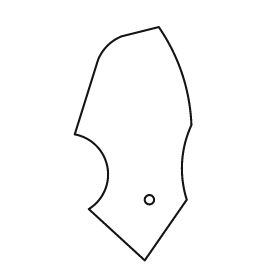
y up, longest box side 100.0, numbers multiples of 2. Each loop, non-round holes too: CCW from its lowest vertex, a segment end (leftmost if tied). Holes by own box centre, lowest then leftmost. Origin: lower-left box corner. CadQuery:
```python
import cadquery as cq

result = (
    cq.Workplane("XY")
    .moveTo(30.0, 0.0)
    .lineTo(48.0, 26.0)
    .threePointArc((46.0, 42.0), (50.0, 58.0))
    .threePointArc((46.0, 80.0), (36.0, 100.0))
    .lineTo(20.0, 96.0)
    .threePointArc((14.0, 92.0), (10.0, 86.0))
    .lineTo(0.0, 54.0)
    .threePointArc((14.0, 40.0), (6.0, 22.0))
    .close()
    .moveTo(32.0, 26.0)
    .circle(2.0)
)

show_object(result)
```